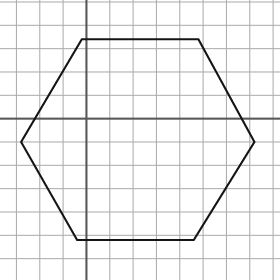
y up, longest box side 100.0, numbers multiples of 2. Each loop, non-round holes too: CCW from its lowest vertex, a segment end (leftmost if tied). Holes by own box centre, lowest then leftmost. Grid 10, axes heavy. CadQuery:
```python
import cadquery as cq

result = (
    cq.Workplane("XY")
    .moveTo(-4.0, -52.0)
    .lineTo(46.0, -52.0)
    .lineTo(72.0, -10.0)
    .lineTo(48.0, 34.0)
    .lineTo(-2.0, 34.0)
    .lineTo(-28.0, -10.0)
    .close()
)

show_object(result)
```